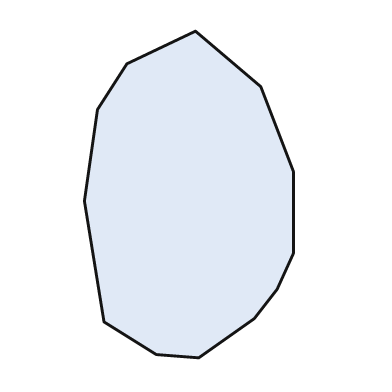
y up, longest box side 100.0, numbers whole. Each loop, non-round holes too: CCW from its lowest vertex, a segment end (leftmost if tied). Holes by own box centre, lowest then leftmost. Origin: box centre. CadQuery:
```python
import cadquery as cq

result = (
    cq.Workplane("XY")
    .moveTo(3.0, -50.0)
    .lineTo(20.0, -38.0)
    .lineTo(27.0, -29.0)
    .lineTo(32.0, -18.0)
    .lineTo(32.0, 7.0)
    .lineTo(22.0, 33.0)
    .lineTo(2.0, 50.0)
    .lineTo(-19.0, 40.0)
    .lineTo(-28.0, 26.0)
    .lineTo(-32.0, -2.0)
    .lineTo(-26.0, -39.0)
    .lineTo(-10.0, -49.0)
    .close()
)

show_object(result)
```